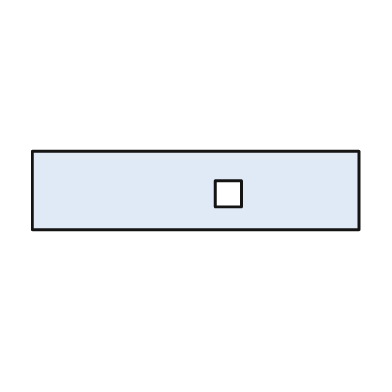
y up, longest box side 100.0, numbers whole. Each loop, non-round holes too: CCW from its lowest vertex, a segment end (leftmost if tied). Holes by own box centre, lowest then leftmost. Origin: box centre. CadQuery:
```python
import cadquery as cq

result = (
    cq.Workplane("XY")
    .moveTo(-50.0, -12.0)
    .lineTo(50.0, -12.0)
    .lineTo(50.0, 12.0)
    .lineTo(-50.0, 12.0)
    .close()
    .moveTo(6.0, -5.0)
    .lineTo(14.0, -5.0)
    .lineTo(14.0, 3.0)
    .lineTo(6.0, 3.0)
    .close()
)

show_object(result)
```